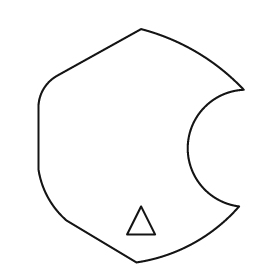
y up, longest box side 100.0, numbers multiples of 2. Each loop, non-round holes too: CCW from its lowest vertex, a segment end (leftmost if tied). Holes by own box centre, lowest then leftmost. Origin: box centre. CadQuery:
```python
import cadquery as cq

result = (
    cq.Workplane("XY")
    .moveTo(-2.0, -50.0)
    .threePointArc((22.0, -42.0), (42.0, -26.0))
    .threePointArc((20.0, 0.0), (44.0, 24.0))
    .threePointArc((24.0, 40.0), (0.0, 50.0))
    .lineTo(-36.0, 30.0)
    .threePointArc((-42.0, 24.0), (-44.0, 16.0))
    .lineTo(-44.0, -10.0)
    .threePointArc((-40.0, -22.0), (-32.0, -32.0))
    .close()
    .moveTo(-6.0, -38.0)
    .lineTo(6.0, -38.0)
    .lineTo(0.0, -26.0)
    .close()
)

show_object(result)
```